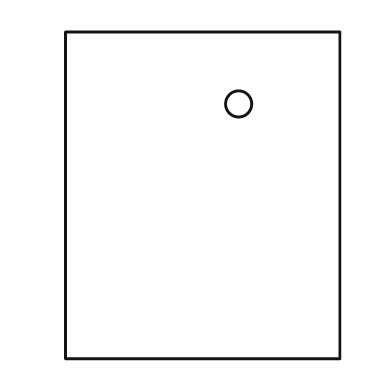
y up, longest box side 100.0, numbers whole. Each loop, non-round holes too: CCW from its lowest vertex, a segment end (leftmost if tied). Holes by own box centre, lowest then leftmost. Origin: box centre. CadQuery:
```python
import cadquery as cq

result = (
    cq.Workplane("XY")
    .moveTo(-42.0, -50.0)
    .lineTo(42.0, -50.0)
    .lineTo(42.0, 50.0)
    .lineTo(-42.0, 50.0)
    .close()
    .moveTo(11.0, 28.0)
    .circle(4.0)
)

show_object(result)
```